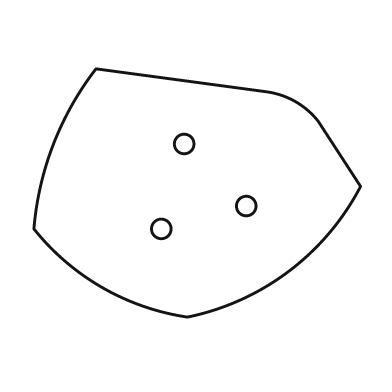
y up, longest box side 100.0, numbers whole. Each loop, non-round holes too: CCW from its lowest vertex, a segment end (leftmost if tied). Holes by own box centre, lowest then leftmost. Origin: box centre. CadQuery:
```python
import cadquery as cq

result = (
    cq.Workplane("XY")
    .moveTo(-3.0, -38.0)
    .threePointArc((28.0, -24.0), (50.0, 2.0))
    .lineTo(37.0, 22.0)
    .threePointArc((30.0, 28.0), (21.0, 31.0))
    .lineTo(-31.0, 38.0)
    .threePointArc((-44.0, 15.0), (-50.0, -11.0))
    .threePointArc((-29.0, -29.0), (-3.0, -38.0))
    .close()
    .moveTo(-11.0, -11.0)
    .circle(3.0)
    .moveTo(15.0, -4.0)
    .circle(3.0)
    .moveTo(-4.0, 15.0)
    .circle(3.0)
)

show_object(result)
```